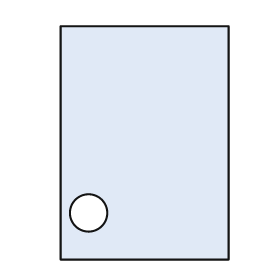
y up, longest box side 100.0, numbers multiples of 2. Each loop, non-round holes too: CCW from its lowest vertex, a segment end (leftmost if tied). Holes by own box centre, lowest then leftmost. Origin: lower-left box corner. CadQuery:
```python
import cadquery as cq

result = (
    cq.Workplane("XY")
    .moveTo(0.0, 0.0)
    .lineTo(72.0, 0.0)
    .lineTo(72.0, 100.0)
    .lineTo(0.0, 100.0)
    .close()
    .moveTo(12.0, 20.0)
    .circle(8.0)
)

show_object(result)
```